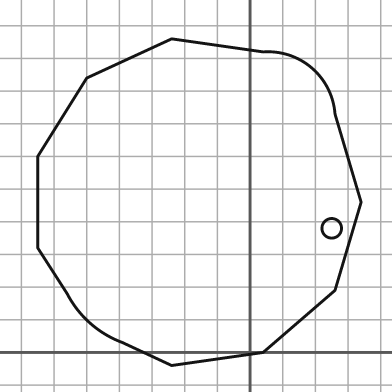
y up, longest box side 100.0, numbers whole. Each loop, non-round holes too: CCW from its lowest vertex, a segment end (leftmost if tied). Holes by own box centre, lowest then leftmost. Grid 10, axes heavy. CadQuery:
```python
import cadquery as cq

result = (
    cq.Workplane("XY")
    .moveTo(-24.0, -4.0)
    .lineTo(4.0, 0.0)
    .lineTo(26.0, 19.0)
    .lineTo(34.0, 46.0)
    .lineTo(26.0, 73.0)
    .threePointArc((19.0, 87.0), (4.0, 92.0))
    .lineTo(-24.0, 96.0)
    .lineTo(-50.0, 84.0)
    .lineTo(-65.0, 60.0)
    .lineTo(-65.0, 32.0)
    .lineTo(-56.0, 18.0)
    .threePointArc((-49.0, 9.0), (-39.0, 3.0))
    .close()
    .moveTo(25.0, 38.0)
    .circle(3.0)
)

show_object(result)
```